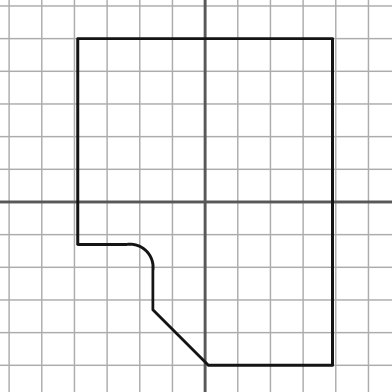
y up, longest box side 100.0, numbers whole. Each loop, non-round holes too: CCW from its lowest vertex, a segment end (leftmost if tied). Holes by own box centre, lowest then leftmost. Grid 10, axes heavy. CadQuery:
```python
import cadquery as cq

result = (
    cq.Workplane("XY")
    .moveTo(1.0, -50.0)
    .lineTo(39.0, -50.0)
    .lineTo(39.0, 50.0)
    .lineTo(-39.0, 50.0)
    .lineTo(-39.0, -13.0)
    .lineTo(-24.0, -13.0)
    .threePointArc((-18.0, -15.0), (-16.0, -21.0))
    .lineTo(-16.0, -33.0)
    .close()
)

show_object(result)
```